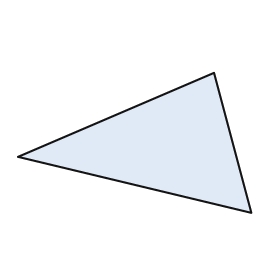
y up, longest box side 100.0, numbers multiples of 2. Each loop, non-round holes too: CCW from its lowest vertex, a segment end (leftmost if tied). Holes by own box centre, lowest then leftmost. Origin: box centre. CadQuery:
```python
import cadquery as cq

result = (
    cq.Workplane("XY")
    .moveTo(50.0, -30.0)
    .lineTo(34.0, 30.0)
    .lineTo(-50.0, -6.0)
    .close()
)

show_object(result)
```